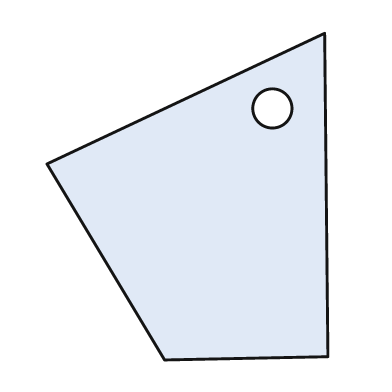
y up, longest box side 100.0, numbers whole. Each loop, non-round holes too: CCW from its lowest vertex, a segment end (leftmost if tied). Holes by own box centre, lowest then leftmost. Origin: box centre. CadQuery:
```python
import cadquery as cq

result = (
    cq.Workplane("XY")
    .moveTo(-7.0, -50.0)
    .lineTo(43.0, -49.0)
    .lineTo(42.0, 50.0)
    .lineTo(-43.0, 10.0)
    .close()
    .moveTo(26.0, 27.0)
    .circle(6.0)
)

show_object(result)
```